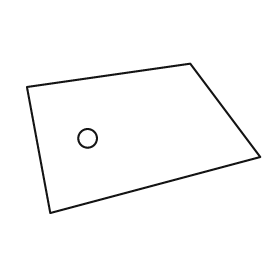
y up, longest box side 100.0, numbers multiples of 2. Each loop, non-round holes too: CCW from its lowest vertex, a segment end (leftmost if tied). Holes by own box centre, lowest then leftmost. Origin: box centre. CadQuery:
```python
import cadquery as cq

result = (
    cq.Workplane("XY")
    .moveTo(-40.0, -32.0)
    .lineTo(50.0, -8.0)
    .lineTo(20.0, 32.0)
    .lineTo(-50.0, 22.0)
    .close()
    .moveTo(-24.0, 0.0)
    .circle(4.0)
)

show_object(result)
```